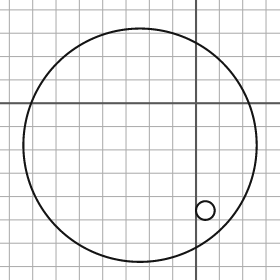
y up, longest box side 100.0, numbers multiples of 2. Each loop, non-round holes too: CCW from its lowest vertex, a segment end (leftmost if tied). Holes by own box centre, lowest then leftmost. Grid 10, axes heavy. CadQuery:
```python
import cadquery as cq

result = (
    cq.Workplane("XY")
    .moveTo(-24.0, -18.0)
    .circle(50.0)
    .moveTo(4.0, -46.0)
    .circle(4.0)
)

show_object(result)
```